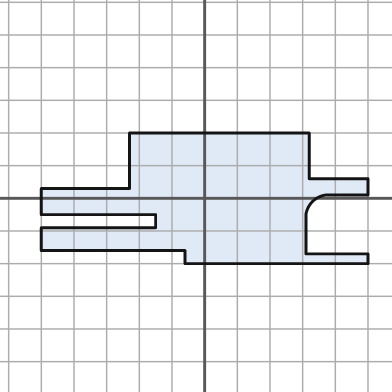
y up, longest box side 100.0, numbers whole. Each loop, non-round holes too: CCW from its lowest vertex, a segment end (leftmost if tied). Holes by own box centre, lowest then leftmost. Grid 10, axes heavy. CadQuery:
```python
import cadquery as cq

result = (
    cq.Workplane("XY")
    .moveTo(-6.0, -20.0)
    .lineTo(50.0, -20.0)
    .lineTo(50.0, -17.0)
    .lineTo(31.0, -17.0)
    .lineTo(31.0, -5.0)
    .threePointArc((33.0, -1.0), (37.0, 1.0))
    .lineTo(50.0, 1.0)
    .lineTo(50.0, 6.0)
    .lineTo(32.0, 6.0)
    .lineTo(32.0, 20.0)
    .lineTo(-23.0, 20.0)
    .lineTo(-23.0, 3.0)
    .lineTo(-50.0, 3.0)
    .lineTo(-50.0, -5.0)
    .lineTo(-15.0, -5.0)
    .lineTo(-15.0, -9.0)
    .lineTo(-50.0, -9.0)
    .lineTo(-50.0, -16.0)
    .lineTo(-6.0, -16.0)
    .close()
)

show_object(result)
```